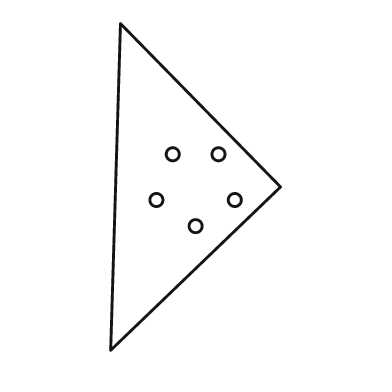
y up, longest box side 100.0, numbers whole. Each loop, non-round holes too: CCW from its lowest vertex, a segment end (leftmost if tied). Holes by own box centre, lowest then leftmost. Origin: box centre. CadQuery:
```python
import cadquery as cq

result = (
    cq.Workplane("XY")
    .moveTo(-26.0, -50.0)
    .lineTo(26.0, 0.0)
    .lineTo(-23.0, 50.0)
    .close()
    .moveTo(0.0, -12.0)
    .circle(2.0)
    .moveTo(-12.0, -4.0)
    .circle(2.0)
    .moveTo(12.0, -4.0)
    .circle(2.0)
    .moveTo(-7.0, 10.0)
    .circle(2.0)
    .moveTo(7.0, 10.0)
    .circle(2.0)
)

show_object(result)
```